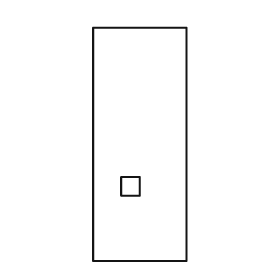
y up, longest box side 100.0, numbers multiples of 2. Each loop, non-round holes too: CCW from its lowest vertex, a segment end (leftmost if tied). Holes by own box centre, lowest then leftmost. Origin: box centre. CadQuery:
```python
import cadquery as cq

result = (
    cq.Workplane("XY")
    .moveTo(-20.0, -50.0)
    .lineTo(20.0, -50.0)
    .lineTo(20.0, 50.0)
    .lineTo(-20.0, 50.0)
    .close()
    .moveTo(-8.0, -22.0)
    .lineTo(0.0, -22.0)
    .lineTo(0.0, -14.0)
    .lineTo(-8.0, -14.0)
    .close()
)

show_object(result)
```